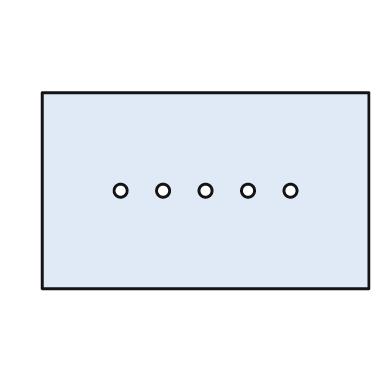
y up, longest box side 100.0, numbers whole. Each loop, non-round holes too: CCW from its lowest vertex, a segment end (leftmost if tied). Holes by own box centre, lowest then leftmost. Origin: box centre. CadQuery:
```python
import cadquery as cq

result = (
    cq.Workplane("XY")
    .moveTo(-50.0, -30.0)
    .lineTo(50.0, -30.0)
    .lineTo(50.0, 30.0)
    .lineTo(-50.0, 30.0)
    .close()
    .moveTo(-26.0, 0.0)
    .circle(2.0)
    .moveTo(-13.0, 0.0)
    .circle(2.0)
    .moveTo(0.0, 0.0)
    .circle(2.0)
    .moveTo(13.0, 0.0)
    .circle(2.0)
    .moveTo(26.0, 0.0)
    .circle(2.0)
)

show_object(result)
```